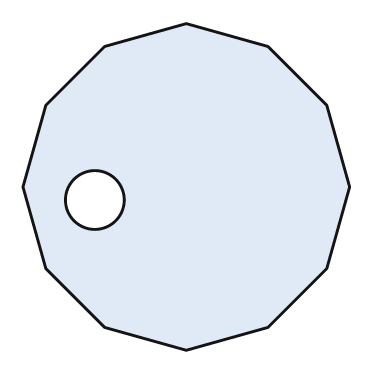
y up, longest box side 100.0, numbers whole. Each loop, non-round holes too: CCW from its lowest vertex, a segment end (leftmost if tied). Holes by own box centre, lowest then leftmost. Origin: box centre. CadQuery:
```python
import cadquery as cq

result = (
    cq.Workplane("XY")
    .moveTo(0.0, -50.0)
    .lineTo(25.0, -43.0)
    .lineTo(43.0, -25.0)
    .lineTo(50.0, 0.0)
    .lineTo(43.0, 25.0)
    .lineTo(25.0, 43.0)
    .lineTo(0.0, 50.0)
    .lineTo(-25.0, 43.0)
    .lineTo(-43.0, 25.0)
    .lineTo(-50.0, 0.0)
    .lineTo(-43.0, -25.0)
    .lineTo(-25.0, -43.0)
    .close()
    .moveTo(-28.0, -4.0)
    .circle(9.0)
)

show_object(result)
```